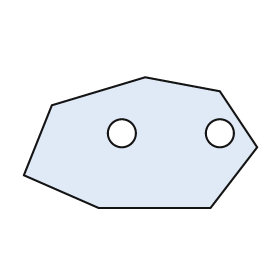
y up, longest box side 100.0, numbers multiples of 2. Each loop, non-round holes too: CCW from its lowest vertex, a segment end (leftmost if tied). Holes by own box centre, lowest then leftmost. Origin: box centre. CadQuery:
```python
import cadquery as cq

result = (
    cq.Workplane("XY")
    .moveTo(-18.0, -28.0)
    .lineTo(30.0, -28.0)
    .lineTo(50.0, -2.0)
    .lineTo(34.0, 22.0)
    .lineTo(2.0, 28.0)
    .lineTo(-38.0, 16.0)
    .lineTo(-50.0, -14.0)
    .close()
    .moveTo(-8.0, 4.0)
    .circle(6.0)
    .moveTo(34.0, 4.0)
    .circle(6.0)
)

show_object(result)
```